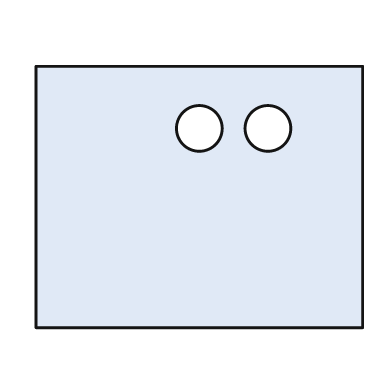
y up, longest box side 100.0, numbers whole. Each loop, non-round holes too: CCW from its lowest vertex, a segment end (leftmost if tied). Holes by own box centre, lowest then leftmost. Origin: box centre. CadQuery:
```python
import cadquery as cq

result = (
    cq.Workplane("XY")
    .moveTo(-50.0, -40.0)
    .lineTo(50.0, -40.0)
    .lineTo(50.0, 40.0)
    .lineTo(-50.0, 40.0)
    .close()
    .moveTo(0.0, 21.0)
    .circle(7.0)
    .moveTo(21.0, 21.0)
    .circle(7.0)
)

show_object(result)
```